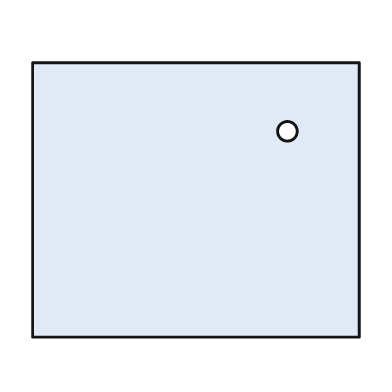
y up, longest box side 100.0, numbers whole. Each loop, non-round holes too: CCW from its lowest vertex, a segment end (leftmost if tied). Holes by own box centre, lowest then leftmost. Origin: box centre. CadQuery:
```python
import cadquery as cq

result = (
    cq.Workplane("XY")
    .moveTo(-50.0, -42.0)
    .lineTo(50.0, -42.0)
    .lineTo(50.0, 42.0)
    .lineTo(-50.0, 42.0)
    .close()
    .moveTo(28.0, 21.0)
    .circle(3.0)
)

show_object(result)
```